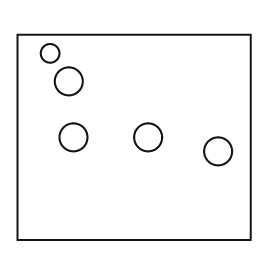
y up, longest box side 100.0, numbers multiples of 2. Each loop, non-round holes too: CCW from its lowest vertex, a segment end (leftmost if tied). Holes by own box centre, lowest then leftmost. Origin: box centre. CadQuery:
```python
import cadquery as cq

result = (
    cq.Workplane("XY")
    .moveTo(-50.0, -44.0)
    .lineTo(50.0, -44.0)
    .lineTo(50.0, 44.0)
    .lineTo(-50.0, 44.0)
    .close()
    .moveTo(36.0, -6.0)
    .circle(6.0)
    .moveTo(-26.0, 0.0)
    .circle(6.0)
    .moveTo(6.0, 0.0)
    .circle(6.0)
    .moveTo(-28.0, 24.0)
    .circle(6.0)
    .moveTo(-36.0, 36.0)
    .circle(4.0)
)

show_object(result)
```